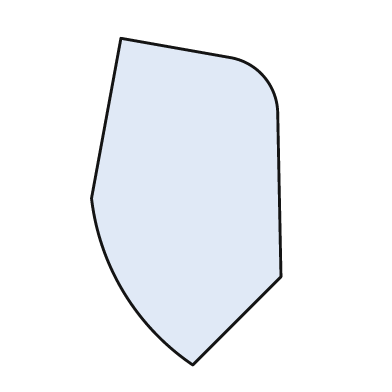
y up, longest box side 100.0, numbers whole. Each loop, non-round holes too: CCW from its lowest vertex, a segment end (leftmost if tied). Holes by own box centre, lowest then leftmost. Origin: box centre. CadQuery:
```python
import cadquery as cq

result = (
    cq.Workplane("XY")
    .moveTo(2.0, -50.0)
    .lineTo(29.0, -23.0)
    .lineTo(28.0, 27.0)
    .threePointArc((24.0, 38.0), (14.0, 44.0))
    .lineTo(-20.0, 50.0)
    .lineTo(-29.0, 1.0)
    .threePointArc((-19.0, -28.0), (2.0, -50.0))
    .close()
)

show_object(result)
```